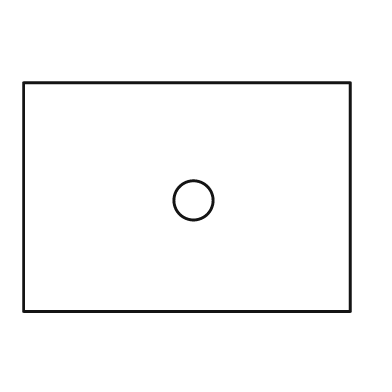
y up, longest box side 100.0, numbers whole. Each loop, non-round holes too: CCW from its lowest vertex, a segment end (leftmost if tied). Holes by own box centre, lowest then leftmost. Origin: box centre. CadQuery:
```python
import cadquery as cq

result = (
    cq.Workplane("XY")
    .moveTo(-50.0, -35.0)
    .lineTo(50.0, -35.0)
    .lineTo(50.0, 35.0)
    .lineTo(-50.0, 35.0)
    .close()
    .moveTo(2.0, -1.0)
    .circle(6.0)
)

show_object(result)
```